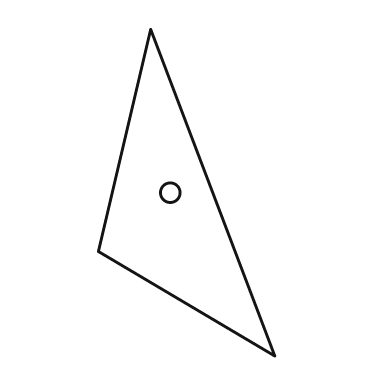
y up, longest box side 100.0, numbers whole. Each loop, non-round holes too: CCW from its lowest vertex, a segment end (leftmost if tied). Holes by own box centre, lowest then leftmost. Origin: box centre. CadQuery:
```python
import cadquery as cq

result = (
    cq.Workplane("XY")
    .moveTo(27.0, -50.0)
    .lineTo(-11.0, 50.0)
    .lineTo(-27.0, -18.0)
    .close()
    .moveTo(-5.0, 0.0)
    .circle(3.0)
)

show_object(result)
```